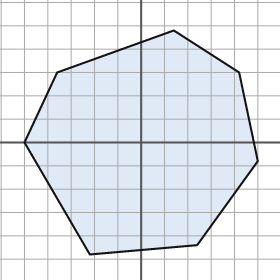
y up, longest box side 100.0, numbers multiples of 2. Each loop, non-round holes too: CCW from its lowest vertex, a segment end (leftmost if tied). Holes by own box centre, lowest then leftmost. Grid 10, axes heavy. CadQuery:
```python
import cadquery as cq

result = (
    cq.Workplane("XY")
    .moveTo(-22.0, -48.0)
    .lineTo(24.0, -44.0)
    .lineTo(50.0, -8.0)
    .lineTo(42.0, 30.0)
    .lineTo(14.0, 48.0)
    .lineTo(-36.0, 30.0)
    .lineTo(-50.0, 0.0)
    .close()
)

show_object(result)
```